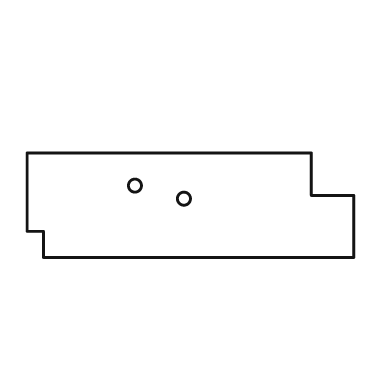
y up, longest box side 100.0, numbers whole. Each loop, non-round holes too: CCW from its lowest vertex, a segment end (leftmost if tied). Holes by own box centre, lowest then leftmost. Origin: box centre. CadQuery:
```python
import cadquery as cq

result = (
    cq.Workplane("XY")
    .moveTo(-45.0, -16.0)
    .lineTo(50.0, -16.0)
    .lineTo(50.0, 3.0)
    .lineTo(37.0, 3.0)
    .lineTo(37.0, 16.0)
    .lineTo(-50.0, 16.0)
    .lineTo(-50.0, -8.0)
    .lineTo(-45.0, -8.0)
    .close()
    .moveTo(-2.0, 2.0)
    .circle(2.0)
    .moveTo(-17.0, 6.0)
    .circle(2.0)
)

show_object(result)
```